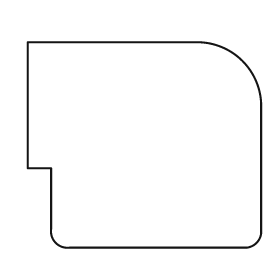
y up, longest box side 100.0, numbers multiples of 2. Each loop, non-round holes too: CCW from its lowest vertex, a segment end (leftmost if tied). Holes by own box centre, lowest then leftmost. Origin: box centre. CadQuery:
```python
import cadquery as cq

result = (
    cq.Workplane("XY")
    .moveTo(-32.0, -44.0)
    .lineTo(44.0, -44.0)
    .threePointArc((48.0, -42.0), (50.0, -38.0))
    .lineTo(50.0, 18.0)
    .threePointArc((42.0, 36.0), (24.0, 44.0))
    .lineTo(-50.0, 44.0)
    .lineTo(-50.0, -10.0)
    .lineTo(-40.0, -10.0)
    .lineTo(-40.0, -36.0)
    .threePointArc((-38.0, -42.0), (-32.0, -44.0))
    .close()
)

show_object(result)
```